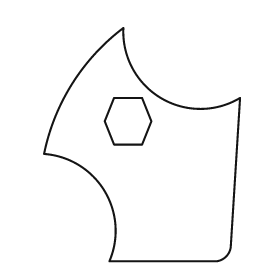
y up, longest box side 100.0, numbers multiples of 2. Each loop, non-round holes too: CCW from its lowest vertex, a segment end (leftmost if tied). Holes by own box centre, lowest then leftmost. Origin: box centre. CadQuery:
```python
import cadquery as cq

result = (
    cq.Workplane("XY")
    .moveTo(-14.0, -50.0)
    .lineTo(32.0, -50.0)
    .threePointArc((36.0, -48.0), (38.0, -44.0))
    .lineTo(42.0, 20.0)
    .threePointArc((8.0, 20.0), (-8.0, 50.0))
    .threePointArc((-30.0, 26.0), (-42.0, -4.0))
    .threePointArc((-16.0, -20.0), (-14.0, -50.0))
    .close()
    .moveTo(-12.0, 0.0)
    .lineTo(0.0, 0.0)
    .lineTo(4.0, 10.0)
    .lineTo(0.0, 20.0)
    .lineTo(-12.0, 20.0)
    .lineTo(-16.0, 10.0)
    .close()
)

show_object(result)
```